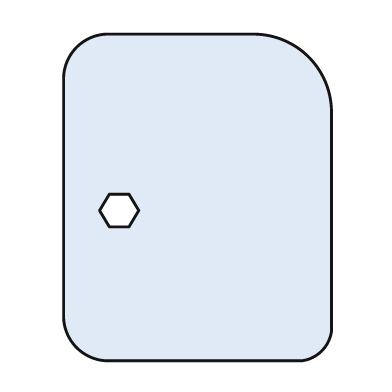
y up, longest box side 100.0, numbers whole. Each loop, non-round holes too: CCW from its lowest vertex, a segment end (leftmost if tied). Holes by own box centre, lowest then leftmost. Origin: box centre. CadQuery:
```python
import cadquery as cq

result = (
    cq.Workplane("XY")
    .moveTo(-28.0, -50.0)
    .lineTo(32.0, -50.0)
    .threePointArc((38.0, -47.0), (41.0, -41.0))
    .lineTo(41.0, 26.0)
    .threePointArc((34.0, 43.0), (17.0, 50.0))
    .lineTo(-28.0, 50.0)
    .threePointArc((-37.0, 46.0), (-41.0, 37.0))
    .lineTo(-41.0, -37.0)
    .threePointArc((-37.0, -46.0), (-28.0, -50.0))
    .close()
    .moveTo(-27.0, -9.0)
    .lineTo(-21.0, -9.0)
    .lineTo(-18.0, -4.0)
    .lineTo(-21.0, 1.0)
    .lineTo(-27.0, 1.0)
    .lineTo(-30.0, -4.0)
    .close()
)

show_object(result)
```